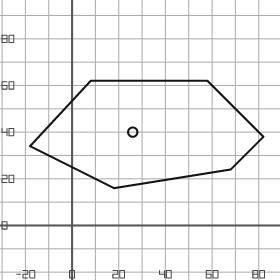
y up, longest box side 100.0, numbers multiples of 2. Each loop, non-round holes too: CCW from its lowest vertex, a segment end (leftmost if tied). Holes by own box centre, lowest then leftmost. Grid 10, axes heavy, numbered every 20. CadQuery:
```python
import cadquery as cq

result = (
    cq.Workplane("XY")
    .moveTo(18.0, 16.0)
    .lineTo(68.0, 24.0)
    .lineTo(82.0, 38.0)
    .lineTo(58.0, 62.0)
    .lineTo(8.0, 62.0)
    .lineTo(-18.0, 34.0)
    .close()
    .moveTo(26.0, 40.0)
    .circle(2.0)
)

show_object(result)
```